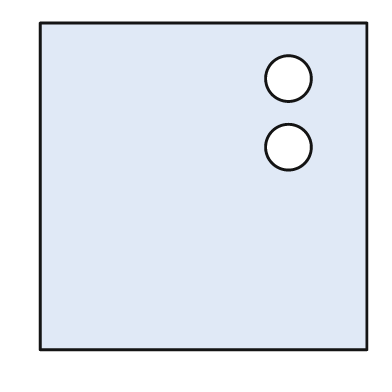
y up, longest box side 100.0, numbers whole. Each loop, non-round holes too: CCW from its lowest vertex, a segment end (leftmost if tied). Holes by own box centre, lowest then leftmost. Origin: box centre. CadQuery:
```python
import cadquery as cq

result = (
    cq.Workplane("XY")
    .moveTo(-50.0, -50.0)
    .lineTo(50.0, -50.0)
    .lineTo(50.0, 50.0)
    .lineTo(-50.0, 50.0)
    .close()
    .moveTo(26.0, 12.0)
    .circle(7.0)
    .moveTo(26.0, 33.0)
    .circle(7.0)
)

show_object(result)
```